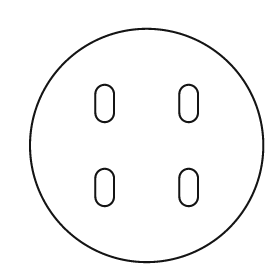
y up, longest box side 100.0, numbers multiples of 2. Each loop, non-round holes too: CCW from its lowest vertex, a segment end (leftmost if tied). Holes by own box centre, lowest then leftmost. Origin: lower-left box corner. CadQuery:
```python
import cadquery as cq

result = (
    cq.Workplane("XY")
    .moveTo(50.0, 50.0)
    .circle(50.0)
    .moveTo(28.0, 28.0)
    .threePointArc((32.0, 24.0), (36.0, 28.0))
    .lineTo(36.0, 36.0)
    .threePointArc((32.0, 40.0), (28.0, 36.0))
    .close()
    .moveTo(64.0, 28.0)
    .threePointArc((68.0, 24.0), (72.0, 28.0))
    .lineTo(72.0, 36.0)
    .threePointArc((68.0, 40.0), (64.0, 36.0))
    .close()
    .moveTo(28.0, 64.0)
    .threePointArc((32.0, 60.0), (36.0, 64.0))
    .lineTo(36.0, 72.0)
    .threePointArc((32.0, 76.0), (28.0, 72.0))
    .close()
    .moveTo(64.0, 64.0)
    .threePointArc((68.0, 60.0), (72.0, 64.0))
    .lineTo(72.0, 72.0)
    .threePointArc((68.0, 76.0), (64.0, 72.0))
    .close()
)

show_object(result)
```